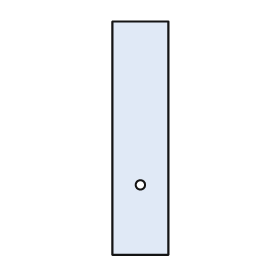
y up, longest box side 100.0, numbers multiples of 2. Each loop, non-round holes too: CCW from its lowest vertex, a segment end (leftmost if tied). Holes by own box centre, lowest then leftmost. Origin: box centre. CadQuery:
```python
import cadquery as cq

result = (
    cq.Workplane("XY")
    .moveTo(-12.0, -50.0)
    .lineTo(12.0, -50.0)
    .lineTo(12.0, 50.0)
    .lineTo(-12.0, 50.0)
    .close()
    .moveTo(0.0, -20.0)
    .circle(2.0)
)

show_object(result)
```